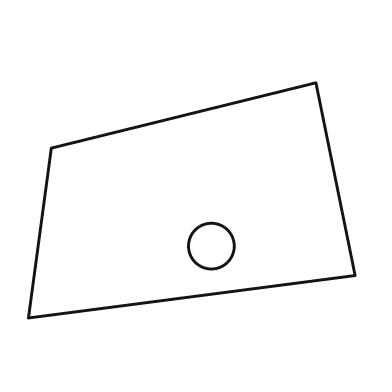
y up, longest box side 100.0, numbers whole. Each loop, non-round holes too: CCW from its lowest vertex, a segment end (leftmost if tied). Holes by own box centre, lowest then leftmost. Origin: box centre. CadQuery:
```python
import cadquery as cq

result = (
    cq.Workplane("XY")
    .moveTo(-50.0, -36.0)
    .lineTo(50.0, -23.0)
    .lineTo(38.0, 36.0)
    .lineTo(-43.0, 16.0)
    .close()
    .moveTo(6.0, -14.0)
    .circle(7.0)
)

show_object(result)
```